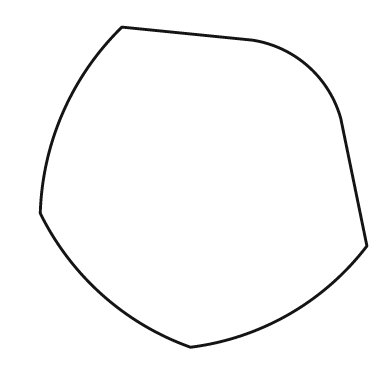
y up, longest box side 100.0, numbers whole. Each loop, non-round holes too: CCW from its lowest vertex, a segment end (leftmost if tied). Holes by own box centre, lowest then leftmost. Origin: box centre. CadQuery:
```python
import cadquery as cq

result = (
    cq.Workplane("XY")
    .moveTo(-4.0, -49.0)
    .threePointArc((26.0, -39.0), (50.0, -18.0))
    .lineTo(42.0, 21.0)
    .threePointArc((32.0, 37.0), (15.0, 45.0))
    .lineTo(-25.0, 49.0)
    .threePointArc((-43.0, 23.0), (-50.0, -8.0))
    .threePointArc((-31.0, -33.0), (-4.0, -49.0))
    .close()
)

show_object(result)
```